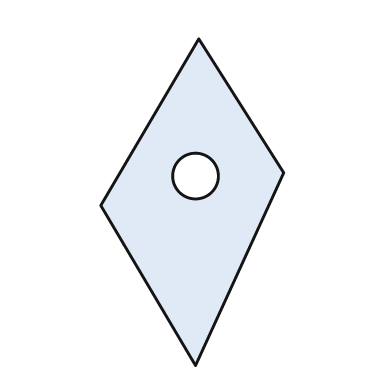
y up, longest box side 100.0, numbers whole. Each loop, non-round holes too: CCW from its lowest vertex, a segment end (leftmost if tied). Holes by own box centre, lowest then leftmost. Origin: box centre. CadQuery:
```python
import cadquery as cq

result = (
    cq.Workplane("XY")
    .moveTo(1.0, -50.0)
    .lineTo(28.0, 9.0)
    .lineTo(2.0, 50.0)
    .lineTo(-28.0, -1.0)
    .close()
    .moveTo(1.0, 8.0)
    .circle(7.0)
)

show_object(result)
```